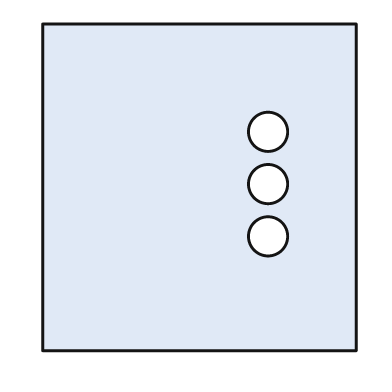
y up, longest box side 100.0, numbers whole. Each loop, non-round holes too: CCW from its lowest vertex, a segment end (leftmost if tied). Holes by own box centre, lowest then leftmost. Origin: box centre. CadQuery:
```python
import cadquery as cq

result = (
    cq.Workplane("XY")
    .moveTo(-48.0, -50.0)
    .lineTo(48.0, -50.0)
    .lineTo(48.0, 50.0)
    .lineTo(-48.0, 50.0)
    .close()
    .moveTo(21.0, -15.0)
    .circle(6.0)
    .moveTo(21.0, 1.0)
    .circle(6.0)
    .moveTo(21.0, 17.0)
    .circle(6.0)
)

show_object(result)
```